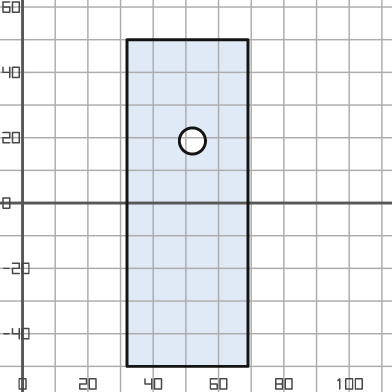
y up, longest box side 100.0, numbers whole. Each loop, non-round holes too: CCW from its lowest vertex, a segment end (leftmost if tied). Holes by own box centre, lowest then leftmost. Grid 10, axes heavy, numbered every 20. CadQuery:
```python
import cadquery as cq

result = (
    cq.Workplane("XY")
    .moveTo(32.0, -50.0)
    .lineTo(69.0, -50.0)
    .lineTo(69.0, 50.0)
    .lineTo(32.0, 50.0)
    .close()
    .moveTo(52.0, 19.0)
    .circle(4.0)
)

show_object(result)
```